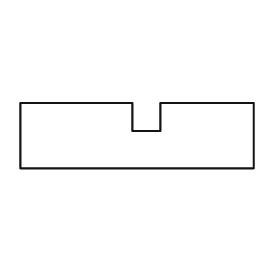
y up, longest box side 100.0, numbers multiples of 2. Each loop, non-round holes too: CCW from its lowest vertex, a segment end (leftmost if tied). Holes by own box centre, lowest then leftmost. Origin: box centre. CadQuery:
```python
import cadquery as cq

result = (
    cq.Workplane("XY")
    .moveTo(-50.0, -14.0)
    .lineTo(50.0, -14.0)
    .lineTo(50.0, 14.0)
    .lineTo(10.0, 14.0)
    .lineTo(10.0, 2.0)
    .lineTo(-2.0, 2.0)
    .lineTo(-2.0, 14.0)
    .lineTo(-50.0, 14.0)
    .close()
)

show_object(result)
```